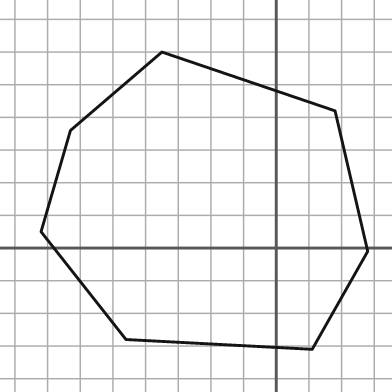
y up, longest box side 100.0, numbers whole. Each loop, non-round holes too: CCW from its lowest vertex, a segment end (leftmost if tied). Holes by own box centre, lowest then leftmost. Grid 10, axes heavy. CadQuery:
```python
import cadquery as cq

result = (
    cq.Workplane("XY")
    .moveTo(11.0, -31.0)
    .lineTo(28.0, -1.0)
    .lineTo(18.0, 42.0)
    .lineTo(-35.0, 60.0)
    .lineTo(-63.0, 36.0)
    .lineTo(-72.0, 5.0)
    .lineTo(-46.0, -28.0)
    .close()
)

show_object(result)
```